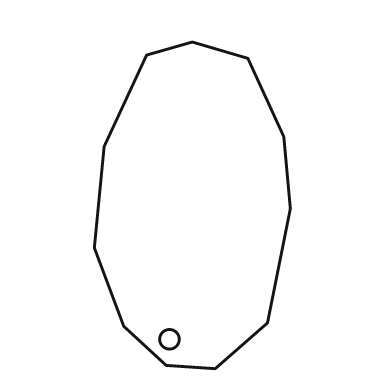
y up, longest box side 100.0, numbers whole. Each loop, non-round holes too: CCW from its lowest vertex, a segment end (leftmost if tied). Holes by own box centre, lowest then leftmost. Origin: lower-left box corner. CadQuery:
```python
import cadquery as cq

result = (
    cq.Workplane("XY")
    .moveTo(37.0, 0.0)
    .lineTo(53.0, 14.0)
    .lineTo(60.0, 49.0)
    .lineTo(58.0, 71.0)
    .lineTo(47.0, 95.0)
    .lineTo(30.0, 100.0)
    .lineTo(16.0, 96.0)
    .lineTo(3.0, 68.0)
    .lineTo(0.0, 37.0)
    .lineTo(9.0, 13.0)
    .lineTo(22.0, 1.0)
    .close()
    .moveTo(23.0, 9.0)
    .circle(3.0)
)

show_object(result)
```